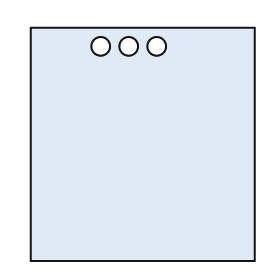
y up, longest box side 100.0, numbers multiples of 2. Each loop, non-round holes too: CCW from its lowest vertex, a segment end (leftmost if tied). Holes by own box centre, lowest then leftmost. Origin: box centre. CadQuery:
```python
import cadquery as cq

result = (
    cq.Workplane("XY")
    .moveTo(-48.0, -50.0)
    .lineTo(48.0, -50.0)
    .lineTo(48.0, 50.0)
    .lineTo(-48.0, 50.0)
    .close()
    .moveTo(-18.0, 42.0)
    .circle(4.0)
    .moveTo(-6.0, 42.0)
    .circle(4.0)
    .moveTo(6.0, 42.0)
    .circle(4.0)
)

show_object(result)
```